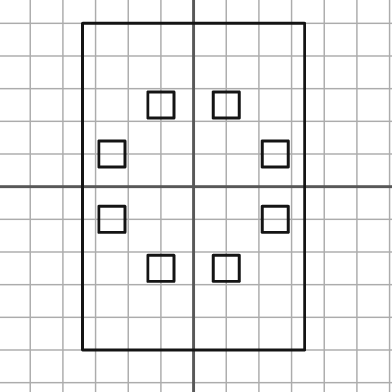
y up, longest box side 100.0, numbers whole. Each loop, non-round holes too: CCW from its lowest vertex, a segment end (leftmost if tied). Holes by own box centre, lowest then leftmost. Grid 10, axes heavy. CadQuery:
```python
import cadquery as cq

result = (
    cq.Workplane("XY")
    .moveTo(-34.0, -50.0)
    .lineTo(34.0, -50.0)
    .lineTo(34.0, 50.0)
    .lineTo(-34.0, 50.0)
    .close()
    .moveTo(-14.0, -29.0)
    .lineTo(-6.0, -29.0)
    .lineTo(-6.0, -21.0)
    .lineTo(-14.0, -21.0)
    .close()
    .moveTo(6.0, -29.0)
    .lineTo(14.0, -29.0)
    .lineTo(14.0, -21.0)
    .lineTo(6.0, -21.0)
    .close()
    .moveTo(-29.0, -14.0)
    .lineTo(-21.0, -14.0)
    .lineTo(-21.0, -6.0)
    .lineTo(-29.0, -6.0)
    .close()
    .moveTo(21.0, -14.0)
    .lineTo(29.0, -14.0)
    .lineTo(29.0, -6.0)
    .lineTo(21.0, -6.0)
    .close()
    .moveTo(-29.0, 6.0)
    .lineTo(-21.0, 6.0)
    .lineTo(-21.0, 14.0)
    .lineTo(-29.0, 14.0)
    .close()
    .moveTo(21.0, 6.0)
    .lineTo(29.0, 6.0)
    .lineTo(29.0, 14.0)
    .lineTo(21.0, 14.0)
    .close()
    .moveTo(-14.0, 21.0)
    .lineTo(-6.0, 21.0)
    .lineTo(-6.0, 29.0)
    .lineTo(-14.0, 29.0)
    .close()
    .moveTo(6.0, 21.0)
    .lineTo(14.0, 21.0)
    .lineTo(14.0, 29.0)
    .lineTo(6.0, 29.0)
    .close()
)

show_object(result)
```